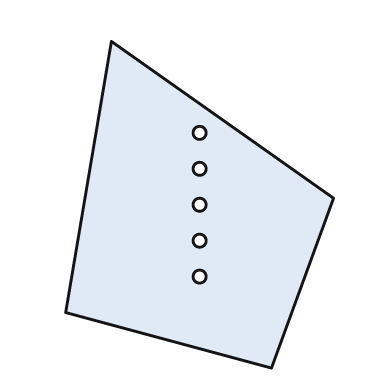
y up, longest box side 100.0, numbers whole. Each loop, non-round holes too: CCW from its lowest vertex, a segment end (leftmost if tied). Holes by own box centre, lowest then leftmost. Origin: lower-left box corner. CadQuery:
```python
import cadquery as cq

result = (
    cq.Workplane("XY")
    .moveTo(63.0, 0.0)
    .lineTo(82.0, 52.0)
    .lineTo(14.0, 100.0)
    .lineTo(0.0, 17.0)
    .close()
    .moveTo(41.0, 28.0)
    .circle(2.0)
    .moveTo(41.0, 39.0)
    .circle(2.0)
    .moveTo(41.0, 50.0)
    .circle(2.0)
    .moveTo(41.0, 61.0)
    .circle(2.0)
    .moveTo(41.0, 72.0)
    .circle(2.0)
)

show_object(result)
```